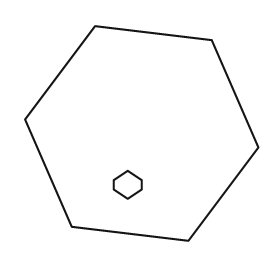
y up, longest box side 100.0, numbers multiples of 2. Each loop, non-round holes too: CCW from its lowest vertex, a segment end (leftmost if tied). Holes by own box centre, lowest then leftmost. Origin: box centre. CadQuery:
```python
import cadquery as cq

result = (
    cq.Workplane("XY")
    .moveTo(20.0, -46.0)
    .lineTo(50.0, -6.0)
    .lineTo(30.0, 40.0)
    .lineTo(-20.0, 46.0)
    .lineTo(-50.0, 6.0)
    .lineTo(-30.0, -40.0)
    .close()
    .moveTo(-6.0, -28.0)
    .lineTo(0.0, -24.0)
    .lineTo(0.0, -20.0)
    .lineTo(-6.0, -16.0)
    .lineTo(-12.0, -20.0)
    .lineTo(-12.0, -24.0)
    .close()
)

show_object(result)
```